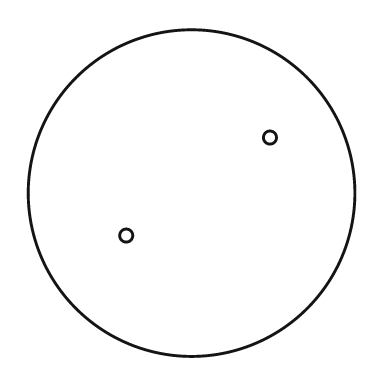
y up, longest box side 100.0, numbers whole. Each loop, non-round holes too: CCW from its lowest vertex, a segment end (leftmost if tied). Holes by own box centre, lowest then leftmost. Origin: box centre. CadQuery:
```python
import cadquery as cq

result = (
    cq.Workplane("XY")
    .moveTo(0.0, 0.0)
    .circle(50.0)
    .moveTo(-20.0, -13.0)
    .circle(2.0)
    .moveTo(24.0, 17.0)
    .circle(2.0)
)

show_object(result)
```